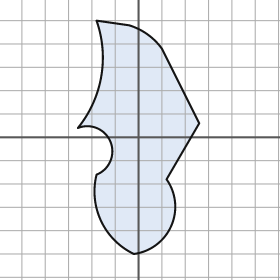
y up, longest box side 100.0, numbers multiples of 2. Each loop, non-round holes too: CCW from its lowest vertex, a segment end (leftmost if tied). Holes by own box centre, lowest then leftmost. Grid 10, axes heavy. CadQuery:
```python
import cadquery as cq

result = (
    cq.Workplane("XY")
    .moveTo(-2.0, -50.0)
    .threePointArc((14.0, -38.0), (12.0, -18.0))
    .lineTo(26.0, 6.0)
    .lineTo(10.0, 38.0)
    .threePointArc((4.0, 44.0), (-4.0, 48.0))
    .lineTo(-18.0, 50.0)
    .threePointArc((-16.0, 26.0), (-26.0, 4.0))
    .threePointArc((-12.0, -2.0), (-18.0, -16.0))
    .threePointArc((-16.0, -36.0), (-2.0, -50.0))
    .close()
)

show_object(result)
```